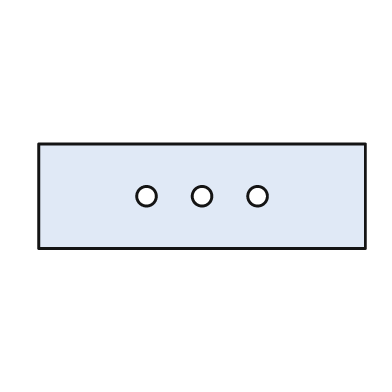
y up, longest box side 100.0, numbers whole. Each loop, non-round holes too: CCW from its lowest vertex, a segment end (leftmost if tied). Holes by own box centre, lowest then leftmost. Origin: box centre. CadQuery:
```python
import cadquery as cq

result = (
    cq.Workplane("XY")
    .moveTo(-50.0, -16.0)
    .lineTo(50.0, -16.0)
    .lineTo(50.0, 16.0)
    .lineTo(-50.0, 16.0)
    .close()
    .moveTo(-17.0, 0.0)
    .circle(3.0)
    .moveTo(0.0, 0.0)
    .circle(3.0)
    .moveTo(17.0, 0.0)
    .circle(3.0)
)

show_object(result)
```